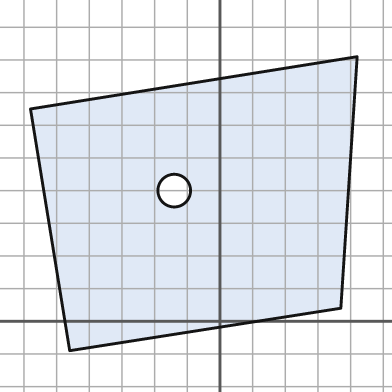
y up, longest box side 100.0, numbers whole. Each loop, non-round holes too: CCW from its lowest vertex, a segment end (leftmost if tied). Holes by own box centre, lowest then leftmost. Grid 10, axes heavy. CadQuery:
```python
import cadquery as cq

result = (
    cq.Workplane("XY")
    .moveTo(-46.0, -9.0)
    .lineTo(37.0, 4.0)
    .lineTo(42.0, 81.0)
    .lineTo(-58.0, 65.0)
    .close()
    .moveTo(-14.0, 40.0)
    .circle(5.0)
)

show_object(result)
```